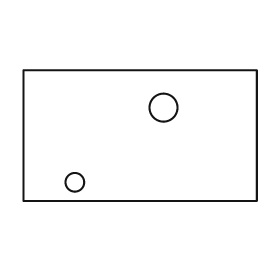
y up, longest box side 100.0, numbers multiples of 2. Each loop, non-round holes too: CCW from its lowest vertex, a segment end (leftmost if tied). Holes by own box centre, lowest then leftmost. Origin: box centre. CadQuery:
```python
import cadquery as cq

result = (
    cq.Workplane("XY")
    .moveTo(-50.0, -28.0)
    .lineTo(50.0, -28.0)
    .lineTo(50.0, 28.0)
    .lineTo(-50.0, 28.0)
    .close()
    .moveTo(-28.0, -20.0)
    .circle(4.0)
    .moveTo(10.0, 12.0)
    .circle(6.0)
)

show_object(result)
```